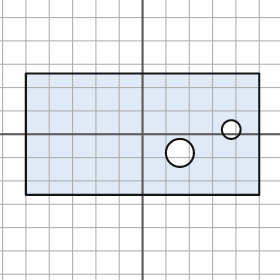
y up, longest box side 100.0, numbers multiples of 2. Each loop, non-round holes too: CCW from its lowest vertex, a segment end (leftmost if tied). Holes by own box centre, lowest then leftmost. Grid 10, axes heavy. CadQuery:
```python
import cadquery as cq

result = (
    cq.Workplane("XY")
    .moveTo(-50.0, -26.0)
    .lineTo(50.0, -26.0)
    .lineTo(50.0, 26.0)
    .lineTo(-50.0, 26.0)
    .close()
    .moveTo(16.0, -8.0)
    .circle(6.0)
    .moveTo(38.0, 2.0)
    .circle(4.0)
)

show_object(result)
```